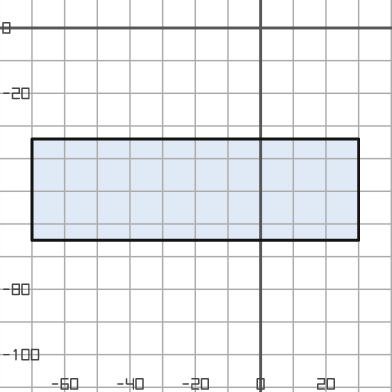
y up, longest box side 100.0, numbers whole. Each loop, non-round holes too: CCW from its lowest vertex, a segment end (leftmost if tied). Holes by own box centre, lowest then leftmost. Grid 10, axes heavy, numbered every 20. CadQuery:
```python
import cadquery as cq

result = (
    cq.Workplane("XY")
    .moveTo(-70.0, -65.0)
    .lineTo(30.0, -65.0)
    .lineTo(30.0, -34.0)
    .lineTo(-70.0, -34.0)
    .close()
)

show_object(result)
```